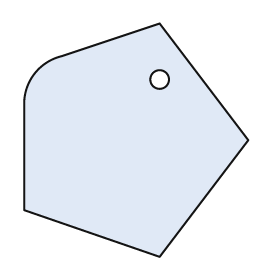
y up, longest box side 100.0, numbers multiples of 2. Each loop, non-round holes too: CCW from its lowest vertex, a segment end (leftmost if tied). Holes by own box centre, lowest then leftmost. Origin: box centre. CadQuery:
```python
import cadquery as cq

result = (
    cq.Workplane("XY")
    .moveTo(10.0, -50.0)
    .lineTo(48.0, 0.0)
    .lineTo(10.0, 50.0)
    .lineTo(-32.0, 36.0)
    .threePointArc((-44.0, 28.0), (-48.0, 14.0))
    .lineTo(-48.0, -30.0)
    .close()
    .moveTo(10.0, 26.0)
    .circle(4.0)
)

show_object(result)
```